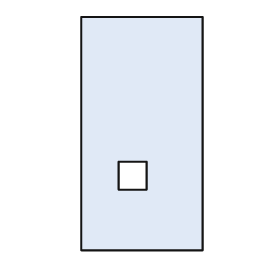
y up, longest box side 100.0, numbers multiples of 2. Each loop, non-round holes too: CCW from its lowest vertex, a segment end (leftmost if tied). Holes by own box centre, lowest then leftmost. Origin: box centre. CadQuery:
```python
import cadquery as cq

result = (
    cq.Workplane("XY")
    .moveTo(-26.0, -50.0)
    .lineTo(26.0, -50.0)
    .lineTo(26.0, 50.0)
    .lineTo(-26.0, 50.0)
    .close()
    .moveTo(-10.0, -24.0)
    .lineTo(2.0, -24.0)
    .lineTo(2.0, -12.0)
    .lineTo(-10.0, -12.0)
    .close()
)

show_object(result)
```